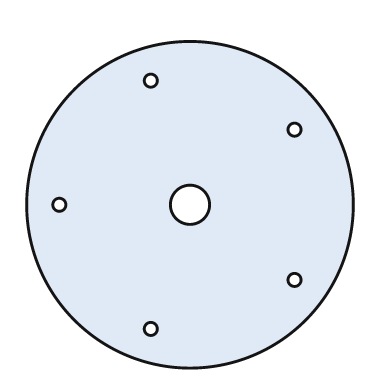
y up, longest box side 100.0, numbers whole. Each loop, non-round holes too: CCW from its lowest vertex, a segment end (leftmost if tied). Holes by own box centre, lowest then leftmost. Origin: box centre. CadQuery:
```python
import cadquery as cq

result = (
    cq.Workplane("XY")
    .moveTo(0.0, 0.0)
    .circle(50.0)
    .moveTo(-12.0, -38.0)
    .circle(2.0)
    .moveTo(32.0, -23.0)
    .circle(2.0)
    .moveTo(-40.0, 0.0)
    .circle(2.0)
    .moveTo(0.0, 0.0)
    .circle(6.0)
    .moveTo(32.0, 23.0)
    .circle(2.0)
    .moveTo(-12.0, 38.0)
    .circle(2.0)
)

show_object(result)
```